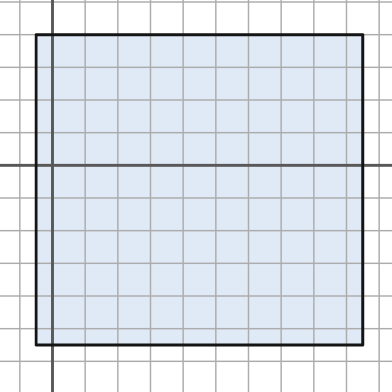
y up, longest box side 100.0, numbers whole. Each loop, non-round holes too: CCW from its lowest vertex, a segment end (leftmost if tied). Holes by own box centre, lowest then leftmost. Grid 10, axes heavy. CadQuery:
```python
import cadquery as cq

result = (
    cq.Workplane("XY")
    .moveTo(-5.0, -55.0)
    .lineTo(95.0, -55.0)
    .lineTo(95.0, 40.0)
    .lineTo(-5.0, 40.0)
    .close()
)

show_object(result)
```